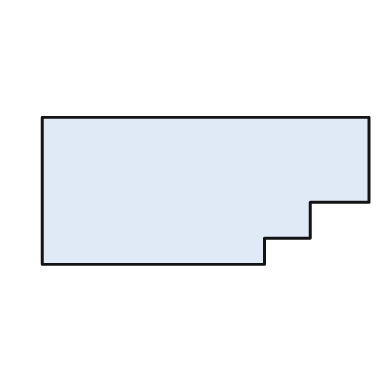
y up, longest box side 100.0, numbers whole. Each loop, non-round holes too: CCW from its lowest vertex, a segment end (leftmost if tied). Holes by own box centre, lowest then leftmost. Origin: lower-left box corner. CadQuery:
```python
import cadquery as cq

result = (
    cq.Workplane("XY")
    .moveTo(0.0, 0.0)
    .lineTo(68.0, 0.0)
    .lineTo(68.0, 8.0)
    .lineTo(82.0, 8.0)
    .lineTo(82.0, 19.0)
    .lineTo(100.0, 19.0)
    .lineTo(100.0, 45.0)
    .lineTo(0.0, 45.0)
    .close()
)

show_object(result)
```